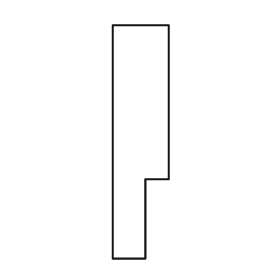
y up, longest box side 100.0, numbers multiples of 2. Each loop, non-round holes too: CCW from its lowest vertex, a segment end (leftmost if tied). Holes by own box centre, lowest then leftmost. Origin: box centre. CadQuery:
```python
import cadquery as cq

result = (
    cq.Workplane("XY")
    .moveTo(-12.0, -50.0)
    .lineTo(2.0, -50.0)
    .lineTo(2.0, -16.0)
    .lineTo(12.0, -16.0)
    .lineTo(12.0, 50.0)
    .lineTo(-12.0, 50.0)
    .close()
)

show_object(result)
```